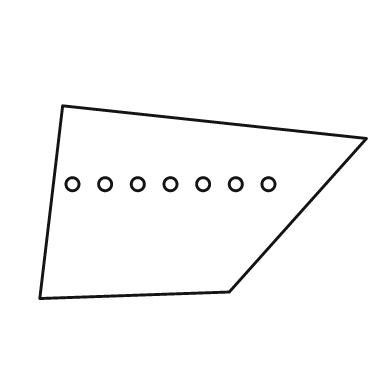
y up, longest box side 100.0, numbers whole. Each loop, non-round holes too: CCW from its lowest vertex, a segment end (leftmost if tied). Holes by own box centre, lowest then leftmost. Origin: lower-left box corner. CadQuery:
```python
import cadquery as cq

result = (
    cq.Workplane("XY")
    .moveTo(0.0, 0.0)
    .lineTo(58.0, 2.0)
    .lineTo(100.0, 49.0)
    .lineTo(7.0, 59.0)
    .close()
    .moveTo(10.0, 35.0)
    .circle(2.0)
    .moveTo(20.0, 35.0)
    .circle(2.0)
    .moveTo(30.0, 35.0)
    .circle(2.0)
    .moveTo(40.0, 35.0)
    .circle(2.0)
    .moveTo(50.0, 35.0)
    .circle(2.0)
    .moveTo(60.0, 35.0)
    .circle(2.0)
    .moveTo(70.0, 35.0)
    .circle(2.0)
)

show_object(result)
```